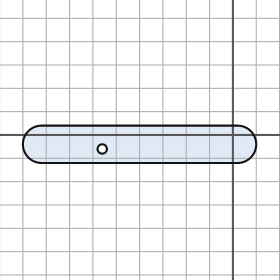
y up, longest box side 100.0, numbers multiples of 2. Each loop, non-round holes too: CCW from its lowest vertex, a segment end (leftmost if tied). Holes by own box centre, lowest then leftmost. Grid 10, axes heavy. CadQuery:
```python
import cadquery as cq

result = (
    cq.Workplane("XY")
    .moveTo(-82.0, -12.0)
    .lineTo(2.0, -12.0)
    .threePointArc((10.0, -4.0), (2.0, 4.0))
    .lineTo(-82.0, 4.0)
    .threePointArc((-90.0, -4.0), (-82.0, -12.0))
    .close()
    .moveTo(-56.0, -6.0)
    .circle(2.0)
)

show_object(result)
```